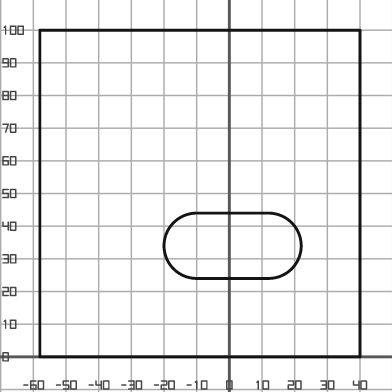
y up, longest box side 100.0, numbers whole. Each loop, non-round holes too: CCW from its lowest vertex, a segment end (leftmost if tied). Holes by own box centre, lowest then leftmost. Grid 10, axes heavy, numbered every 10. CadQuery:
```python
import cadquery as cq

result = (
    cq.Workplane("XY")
    .moveTo(-58.0, 0.0)
    .lineTo(40.0, 0.0)
    .lineTo(40.0, 100.0)
    .lineTo(-58.0, 100.0)
    .close()
    .moveTo(-10.0, 24.0)
    .lineTo(12.0, 24.0)
    .threePointArc((22.0, 34.0), (12.0, 44.0))
    .lineTo(-10.0, 44.0)
    .threePointArc((-20.0, 34.0), (-10.0, 24.0))
    .close()
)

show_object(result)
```